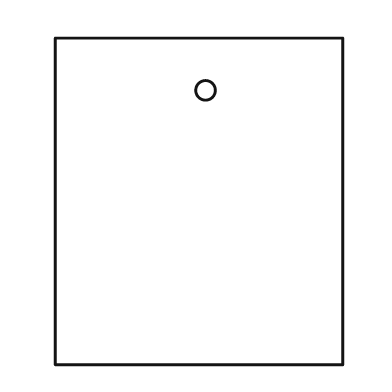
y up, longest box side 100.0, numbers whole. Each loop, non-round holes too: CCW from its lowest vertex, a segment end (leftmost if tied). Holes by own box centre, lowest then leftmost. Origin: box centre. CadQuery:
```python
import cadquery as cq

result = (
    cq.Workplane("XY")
    .moveTo(-44.0, -50.0)
    .lineTo(44.0, -50.0)
    .lineTo(44.0, 50.0)
    .lineTo(-44.0, 50.0)
    .close()
    .moveTo(2.0, 34.0)
    .circle(3.0)
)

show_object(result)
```